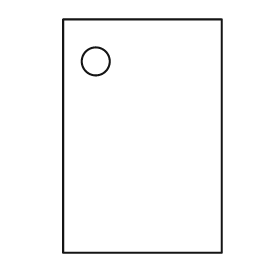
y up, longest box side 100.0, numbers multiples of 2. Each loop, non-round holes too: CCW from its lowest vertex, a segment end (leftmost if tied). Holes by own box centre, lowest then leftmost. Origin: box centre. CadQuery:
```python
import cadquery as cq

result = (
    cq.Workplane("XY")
    .moveTo(-34.0, -50.0)
    .lineTo(34.0, -50.0)
    .lineTo(34.0, 50.0)
    .lineTo(-34.0, 50.0)
    .close()
    .moveTo(-20.0, 32.0)
    .circle(6.0)
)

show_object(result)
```